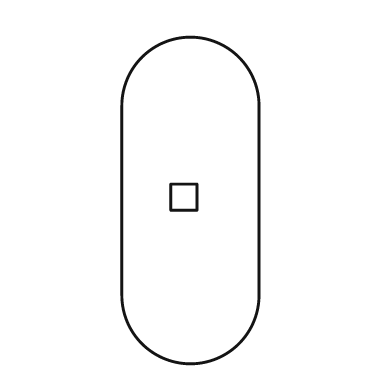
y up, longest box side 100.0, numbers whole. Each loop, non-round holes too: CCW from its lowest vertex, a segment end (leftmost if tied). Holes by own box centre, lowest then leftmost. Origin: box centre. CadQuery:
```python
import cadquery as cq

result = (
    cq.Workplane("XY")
    .moveTo(-21.0, -29.0)
    .threePointArc((0.0, -50.0), (21.0, -29.0))
    .lineTo(21.0, 29.0)
    .threePointArc((0.0, 50.0), (-21.0, 29.0))
    .close()
    .moveTo(-6.0, -3.0)
    .lineTo(2.0, -3.0)
    .lineTo(2.0, 5.0)
    .lineTo(-6.0, 5.0)
    .close()
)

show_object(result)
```